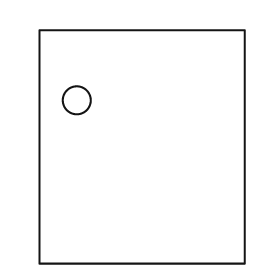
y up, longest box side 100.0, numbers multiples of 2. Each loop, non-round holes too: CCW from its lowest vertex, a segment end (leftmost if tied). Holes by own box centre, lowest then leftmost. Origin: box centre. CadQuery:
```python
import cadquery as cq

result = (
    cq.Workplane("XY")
    .moveTo(-44.0, -50.0)
    .lineTo(44.0, -50.0)
    .lineTo(44.0, 50.0)
    .lineTo(-44.0, 50.0)
    .close()
    .moveTo(-28.0, 20.0)
    .circle(6.0)
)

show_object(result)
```